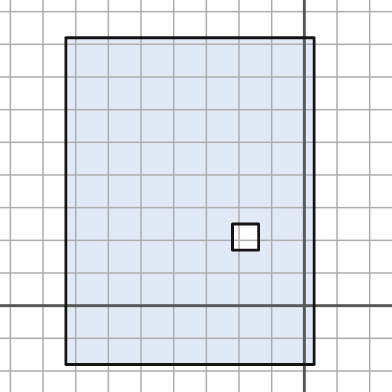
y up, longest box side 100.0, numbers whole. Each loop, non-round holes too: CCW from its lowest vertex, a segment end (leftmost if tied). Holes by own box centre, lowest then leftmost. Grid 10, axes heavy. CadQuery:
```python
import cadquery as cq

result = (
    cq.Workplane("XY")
    .moveTo(-73.0, -18.0)
    .lineTo(3.0, -18.0)
    .lineTo(3.0, 82.0)
    .lineTo(-73.0, 82.0)
    .close()
    .moveTo(-22.0, 17.0)
    .lineTo(-14.0, 17.0)
    .lineTo(-14.0, 25.0)
    .lineTo(-22.0, 25.0)
    .close()
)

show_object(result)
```